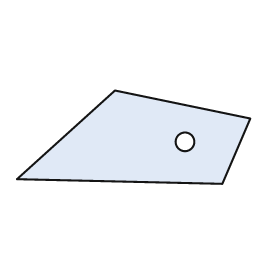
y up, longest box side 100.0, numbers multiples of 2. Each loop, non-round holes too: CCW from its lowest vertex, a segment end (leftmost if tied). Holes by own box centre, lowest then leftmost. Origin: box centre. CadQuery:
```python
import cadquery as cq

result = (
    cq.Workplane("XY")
    .moveTo(38.0, -20.0)
    .lineTo(50.0, 8.0)
    .lineTo(-8.0, 20.0)
    .lineTo(-50.0, -18.0)
    .close()
    .moveTo(22.0, -2.0)
    .circle(4.0)
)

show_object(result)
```